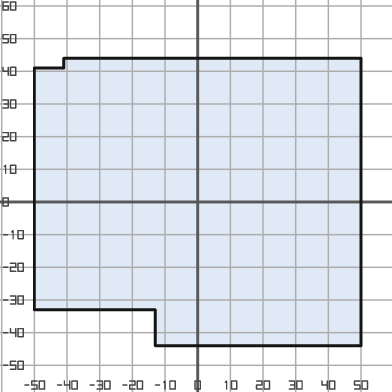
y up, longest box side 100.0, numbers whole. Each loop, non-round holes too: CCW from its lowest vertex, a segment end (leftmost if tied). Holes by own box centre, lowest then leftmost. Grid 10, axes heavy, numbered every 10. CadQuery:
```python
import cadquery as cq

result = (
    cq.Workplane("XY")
    .moveTo(-13.0, -44.0)
    .lineTo(50.0, -44.0)
    .lineTo(50.0, 44.0)
    .lineTo(-41.0, 44.0)
    .lineTo(-41.0, 41.0)
    .lineTo(-50.0, 41.0)
    .lineTo(-50.0, -33.0)
    .lineTo(-13.0, -33.0)
    .close()
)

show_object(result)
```